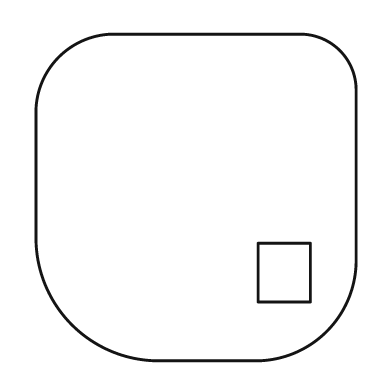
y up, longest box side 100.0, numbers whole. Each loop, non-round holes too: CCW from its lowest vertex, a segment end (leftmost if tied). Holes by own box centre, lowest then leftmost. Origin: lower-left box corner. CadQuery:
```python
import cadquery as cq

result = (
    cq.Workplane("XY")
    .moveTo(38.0, 0.0)
    .lineTo(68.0, 0.0)
    .threePointArc((89.0, 9.0), (98.0, 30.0))
    .lineTo(98.0, 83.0)
    .threePointArc((93.0, 95.0), (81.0, 100.0))
    .lineTo(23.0, 100.0)
    .threePointArc((7.0, 93.0), (0.0, 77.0))
    .lineTo(0.0, 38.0)
    .threePointArc((11.0, 11.0), (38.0, 0.0))
    .close()
    .moveTo(68.0, 18.0)
    .lineTo(84.0, 18.0)
    .lineTo(84.0, 36.0)
    .lineTo(68.0, 36.0)
    .close()
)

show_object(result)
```